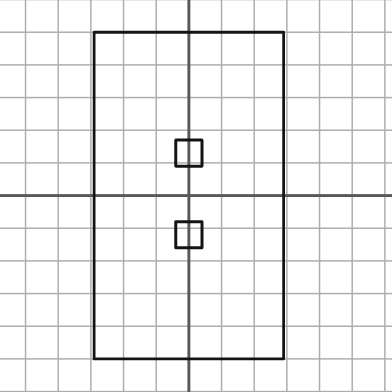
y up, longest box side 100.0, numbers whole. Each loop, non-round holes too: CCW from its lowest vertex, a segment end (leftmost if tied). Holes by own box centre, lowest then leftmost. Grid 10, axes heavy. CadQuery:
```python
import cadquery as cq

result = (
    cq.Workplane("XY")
    .moveTo(-29.0, -50.0)
    .lineTo(29.0, -50.0)
    .lineTo(29.0, 50.0)
    .lineTo(-29.0, 50.0)
    .close()
    .moveTo(-4.0, -16.0)
    .lineTo(4.0, -16.0)
    .lineTo(4.0, -8.0)
    .lineTo(-4.0, -8.0)
    .close()
    .moveTo(-4.0, 9.0)
    .lineTo(4.0, 9.0)
    .lineTo(4.0, 17.0)
    .lineTo(-4.0, 17.0)
    .close()
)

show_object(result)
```